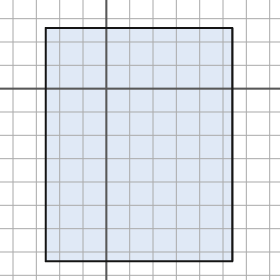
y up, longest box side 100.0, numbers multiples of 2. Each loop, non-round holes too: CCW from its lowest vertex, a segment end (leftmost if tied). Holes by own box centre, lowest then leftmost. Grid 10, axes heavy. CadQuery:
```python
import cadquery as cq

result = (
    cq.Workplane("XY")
    .moveTo(-26.0, -74.0)
    .lineTo(54.0, -74.0)
    .lineTo(54.0, 26.0)
    .lineTo(-26.0, 26.0)
    .close()
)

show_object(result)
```